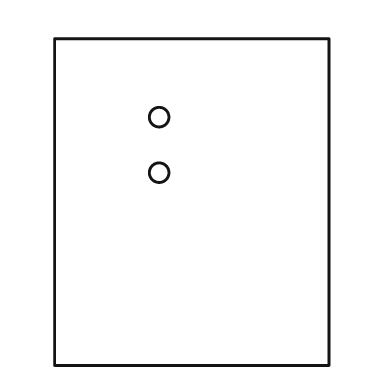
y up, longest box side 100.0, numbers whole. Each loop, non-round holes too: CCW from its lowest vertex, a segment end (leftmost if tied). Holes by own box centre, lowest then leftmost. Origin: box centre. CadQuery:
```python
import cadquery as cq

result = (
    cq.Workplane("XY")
    .moveTo(-42.0, -50.0)
    .lineTo(42.0, -50.0)
    .lineTo(42.0, 50.0)
    .lineTo(-42.0, 50.0)
    .close()
    .moveTo(-10.0, 9.0)
    .circle(3.0)
    .moveTo(-10.0, 26.0)
    .circle(3.0)
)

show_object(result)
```